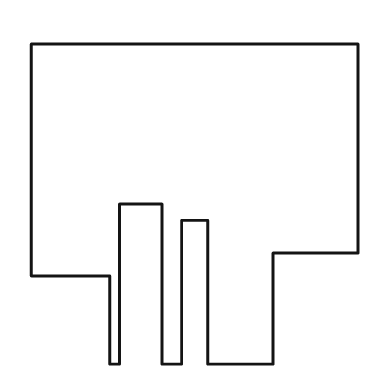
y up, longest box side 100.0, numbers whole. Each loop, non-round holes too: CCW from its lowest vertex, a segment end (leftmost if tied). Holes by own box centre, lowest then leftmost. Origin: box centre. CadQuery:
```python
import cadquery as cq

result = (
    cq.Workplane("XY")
    .moveTo(-26.0, -49.0)
    .lineTo(-23.0, -49.0)
    .lineTo(-23.0, 0.0)
    .lineTo(-10.0, 0.0)
    .lineTo(-10.0, -49.0)
    .lineTo(-4.0, -49.0)
    .lineTo(-4.0, -5.0)
    .lineTo(4.0, -5.0)
    .lineTo(4.0, -49.0)
    .lineTo(24.0, -49.0)
    .lineTo(24.0, -15.0)
    .lineTo(50.0, -15.0)
    .lineTo(50.0, 49.0)
    .lineTo(-50.0, 49.0)
    .lineTo(-50.0, -22.0)
    .lineTo(-26.0, -22.0)
    .close()
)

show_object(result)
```